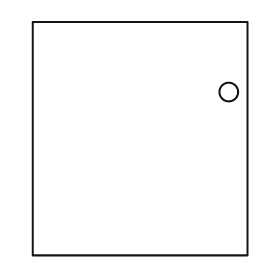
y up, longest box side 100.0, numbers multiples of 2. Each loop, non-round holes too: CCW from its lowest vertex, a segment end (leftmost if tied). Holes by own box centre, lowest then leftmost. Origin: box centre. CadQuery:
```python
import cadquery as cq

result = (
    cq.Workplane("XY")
    .moveTo(-46.0, -50.0)
    .lineTo(46.0, -50.0)
    .lineTo(46.0, 50.0)
    .lineTo(-46.0, 50.0)
    .close()
    .moveTo(38.0, 20.0)
    .circle(4.0)
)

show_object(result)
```